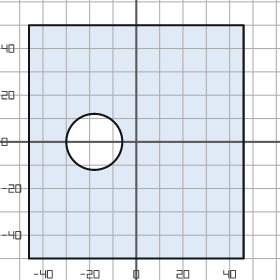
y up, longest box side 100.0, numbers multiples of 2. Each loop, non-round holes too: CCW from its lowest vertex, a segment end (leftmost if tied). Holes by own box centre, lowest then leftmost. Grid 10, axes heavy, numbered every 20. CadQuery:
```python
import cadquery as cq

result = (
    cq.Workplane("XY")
    .moveTo(-46.0, -50.0)
    .lineTo(46.0, -50.0)
    .lineTo(46.0, 50.0)
    .lineTo(-46.0, 50.0)
    .close()
    .moveTo(-18.0, 0.0)
    .circle(12.0)
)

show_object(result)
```